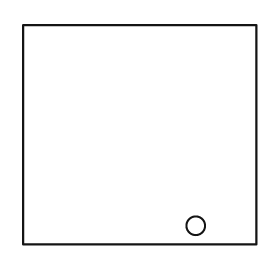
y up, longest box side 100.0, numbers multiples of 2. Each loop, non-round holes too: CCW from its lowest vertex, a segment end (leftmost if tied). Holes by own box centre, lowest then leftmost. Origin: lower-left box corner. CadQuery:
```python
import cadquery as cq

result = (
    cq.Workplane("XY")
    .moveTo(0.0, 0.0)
    .lineTo(100.0, 0.0)
    .lineTo(100.0, 94.0)
    .lineTo(0.0, 94.0)
    .close()
    .moveTo(74.0, 8.0)
    .circle(4.0)
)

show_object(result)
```